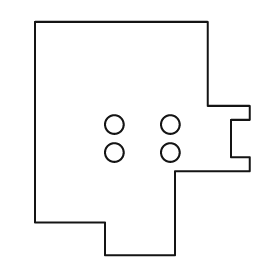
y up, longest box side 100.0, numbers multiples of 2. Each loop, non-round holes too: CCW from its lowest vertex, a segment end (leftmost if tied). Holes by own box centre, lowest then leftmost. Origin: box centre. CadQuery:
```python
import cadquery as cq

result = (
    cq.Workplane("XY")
    .moveTo(-16.0, -50.0)
    .lineTo(14.0, -50.0)
    .lineTo(14.0, -14.0)
    .lineTo(46.0, -14.0)
    .lineTo(46.0, -8.0)
    .lineTo(38.0, -8.0)
    .lineTo(38.0, 8.0)
    .lineTo(46.0, 8.0)
    .lineTo(46.0, 14.0)
    .lineTo(28.0, 14.0)
    .lineTo(28.0, 50.0)
    .lineTo(-46.0, 50.0)
    .lineTo(-46.0, -36.0)
    .lineTo(-16.0, -36.0)
    .close()
    .moveTo(-12.0, -6.0)
    .circle(4.0)
    .moveTo(12.0, -6.0)
    .circle(4.0)
    .moveTo(-12.0, 6.0)
    .circle(4.0)
    .moveTo(12.0, 6.0)
    .circle(4.0)
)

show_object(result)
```